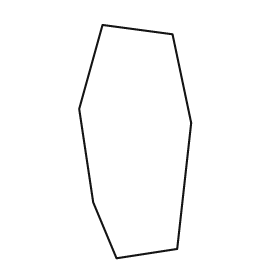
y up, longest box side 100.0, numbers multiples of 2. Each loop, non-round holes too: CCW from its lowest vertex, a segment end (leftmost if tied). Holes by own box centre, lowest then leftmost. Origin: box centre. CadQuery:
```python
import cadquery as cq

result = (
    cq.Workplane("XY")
    .moveTo(-8.0, -50.0)
    .lineTo(18.0, -46.0)
    .lineTo(24.0, 8.0)
    .lineTo(16.0, 46.0)
    .lineTo(-14.0, 50.0)
    .lineTo(-24.0, 14.0)
    .lineTo(-18.0, -26.0)
    .close()
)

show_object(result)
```